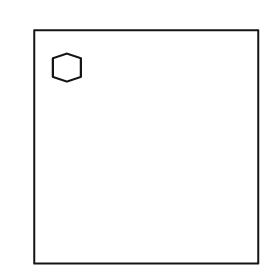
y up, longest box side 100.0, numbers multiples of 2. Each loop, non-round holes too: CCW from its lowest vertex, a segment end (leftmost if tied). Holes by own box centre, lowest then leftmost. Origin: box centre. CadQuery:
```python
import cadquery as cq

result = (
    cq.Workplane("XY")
    .moveTo(-48.0, -50.0)
    .lineTo(48.0, -50.0)
    .lineTo(48.0, 50.0)
    .lineTo(-48.0, 50.0)
    .close()
    .moveTo(-34.0, 28.0)
    .lineTo(-28.0, 30.0)
    .lineTo(-28.0, 38.0)
    .lineTo(-34.0, 40.0)
    .lineTo(-40.0, 38.0)
    .lineTo(-40.0, 30.0)
    .close()
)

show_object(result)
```